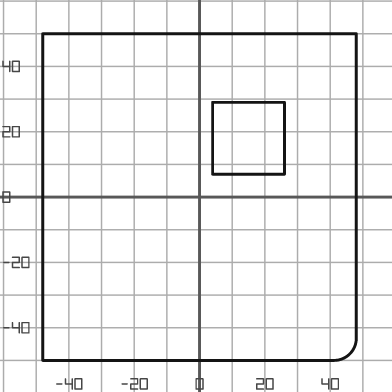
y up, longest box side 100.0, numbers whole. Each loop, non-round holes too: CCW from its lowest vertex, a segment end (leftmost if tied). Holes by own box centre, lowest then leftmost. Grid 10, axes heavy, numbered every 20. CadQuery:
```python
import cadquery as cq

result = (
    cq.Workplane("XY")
    .moveTo(-48.0, -50.0)
    .lineTo(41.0, -50.0)
    .threePointArc((46.0, -48.0), (48.0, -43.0))
    .lineTo(48.0, 50.0)
    .lineTo(-48.0, 50.0)
    .close()
    .moveTo(4.0, 7.0)
    .lineTo(26.0, 7.0)
    .lineTo(26.0, 29.0)
    .lineTo(4.0, 29.0)
    .close()
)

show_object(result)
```